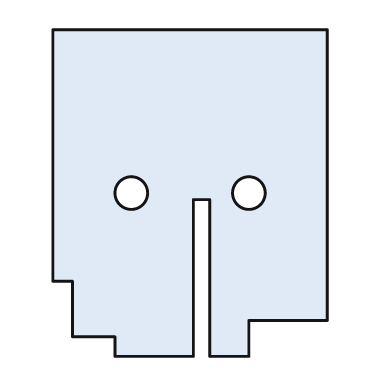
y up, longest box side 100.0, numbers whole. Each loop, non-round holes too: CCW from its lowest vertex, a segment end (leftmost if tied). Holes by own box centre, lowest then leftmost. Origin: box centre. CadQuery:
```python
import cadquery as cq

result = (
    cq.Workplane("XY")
    .moveTo(-23.0, -50.0)
    .lineTo(1.0, -50.0)
    .lineTo(1.0, -2.0)
    .lineTo(6.0, -2.0)
    .lineTo(6.0, -50.0)
    .lineTo(18.0, -50.0)
    .lineTo(18.0, -39.0)
    .lineTo(42.0, -39.0)
    .lineTo(42.0, 50.0)
    .lineTo(-42.0, 50.0)
    .lineTo(-42.0, -27.0)
    .lineTo(-36.0, -27.0)
    .lineTo(-36.0, -44.0)
    .lineTo(-23.0, -44.0)
    .close()
    .moveTo(-18.0, 0.0)
    .circle(5.0)
    .moveTo(18.0, 0.0)
    .circle(5.0)
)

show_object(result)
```